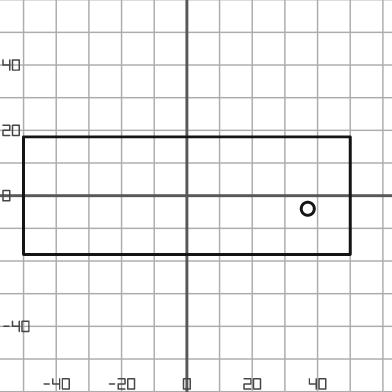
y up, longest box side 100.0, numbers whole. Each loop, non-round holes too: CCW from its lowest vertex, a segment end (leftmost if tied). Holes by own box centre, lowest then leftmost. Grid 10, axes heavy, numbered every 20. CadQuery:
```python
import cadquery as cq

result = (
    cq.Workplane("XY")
    .moveTo(-50.0, -18.0)
    .lineTo(50.0, -18.0)
    .lineTo(50.0, 18.0)
    .lineTo(-50.0, 18.0)
    .close()
    .moveTo(37.0, -4.0)
    .circle(2.0)
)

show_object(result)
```